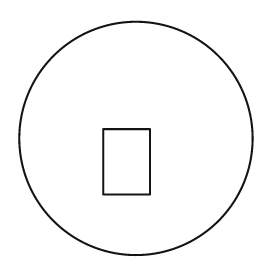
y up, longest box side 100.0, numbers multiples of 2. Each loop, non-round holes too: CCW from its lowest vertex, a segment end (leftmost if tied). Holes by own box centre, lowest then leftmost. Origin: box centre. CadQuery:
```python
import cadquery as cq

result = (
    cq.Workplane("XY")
    .moveTo(0.0, 0.0)
    .circle(50.0)
    .moveTo(-14.0, -24.0)
    .lineTo(6.0, -24.0)
    .lineTo(6.0, 4.0)
    .lineTo(-14.0, 4.0)
    .close()
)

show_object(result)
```